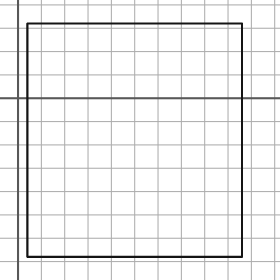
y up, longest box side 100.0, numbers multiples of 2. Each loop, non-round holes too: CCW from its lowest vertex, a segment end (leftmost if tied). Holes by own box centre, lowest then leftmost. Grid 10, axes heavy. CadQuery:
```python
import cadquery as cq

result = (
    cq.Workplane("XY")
    .moveTo(4.0, -68.0)
    .lineTo(96.0, -68.0)
    .lineTo(96.0, 32.0)
    .lineTo(4.0, 32.0)
    .close()
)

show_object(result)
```